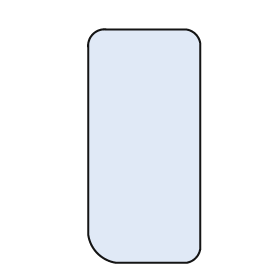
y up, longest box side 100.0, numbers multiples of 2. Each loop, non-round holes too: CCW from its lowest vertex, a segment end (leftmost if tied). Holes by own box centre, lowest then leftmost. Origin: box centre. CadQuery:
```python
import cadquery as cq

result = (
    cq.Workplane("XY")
    .moveTo(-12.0, -50.0)
    .lineTo(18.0, -50.0)
    .threePointArc((22.0, -48.0), (24.0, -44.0))
    .lineTo(24.0, 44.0)
    .threePointArc((22.0, 48.0), (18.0, 50.0))
    .lineTo(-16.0, 50.0)
    .threePointArc((-22.0, 48.0), (-24.0, 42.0))
    .lineTo(-24.0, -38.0)
    .threePointArc((-20.0, -46.0), (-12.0, -50.0))
    .close()
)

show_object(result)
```